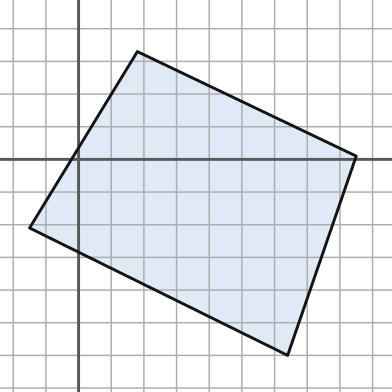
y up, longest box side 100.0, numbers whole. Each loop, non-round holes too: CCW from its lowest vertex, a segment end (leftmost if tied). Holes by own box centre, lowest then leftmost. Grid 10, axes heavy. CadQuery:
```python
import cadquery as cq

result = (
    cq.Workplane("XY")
    .moveTo(64.0, -60.0)
    .lineTo(85.0, 1.0)
    .lineTo(18.0, 33.0)
    .lineTo(-15.0, -21.0)
    .close()
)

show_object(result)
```